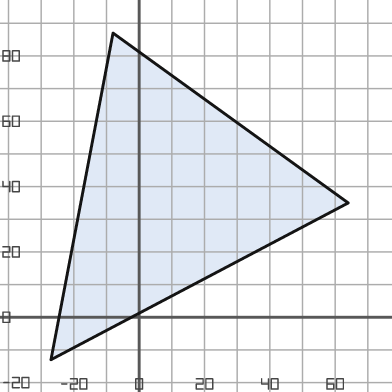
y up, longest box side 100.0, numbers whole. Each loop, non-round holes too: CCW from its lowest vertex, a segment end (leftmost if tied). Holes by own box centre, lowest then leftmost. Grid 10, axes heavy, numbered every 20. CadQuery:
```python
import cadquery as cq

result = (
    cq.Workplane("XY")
    .moveTo(-27.0, -13.0)
    .lineTo(64.0, 35.0)
    .lineTo(-8.0, 87.0)
    .close()
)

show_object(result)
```